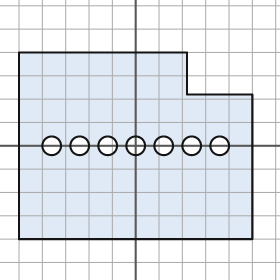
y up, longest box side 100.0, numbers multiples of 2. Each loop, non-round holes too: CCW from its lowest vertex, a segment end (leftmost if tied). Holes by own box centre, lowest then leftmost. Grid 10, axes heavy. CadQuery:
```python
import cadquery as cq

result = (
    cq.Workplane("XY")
    .moveTo(-50.0, -40.0)
    .lineTo(50.0, -40.0)
    .lineTo(50.0, 22.0)
    .lineTo(22.0, 22.0)
    .lineTo(22.0, 40.0)
    .lineTo(-50.0, 40.0)
    .close()
    .moveTo(-36.0, 0.0)
    .circle(4.0)
    .moveTo(-24.0, 0.0)
    .circle(4.0)
    .moveTo(-12.0, 0.0)
    .circle(4.0)
    .moveTo(0.0, 0.0)
    .circle(4.0)
    .moveTo(12.0, 0.0)
    .circle(4.0)
    .moveTo(24.0, 0.0)
    .circle(4.0)
    .moveTo(36.0, 0.0)
    .circle(4.0)
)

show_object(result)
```